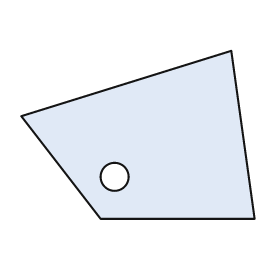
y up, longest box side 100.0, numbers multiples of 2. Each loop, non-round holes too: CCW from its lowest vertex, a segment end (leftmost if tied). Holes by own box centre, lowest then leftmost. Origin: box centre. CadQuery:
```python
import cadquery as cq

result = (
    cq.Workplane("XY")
    .moveTo(-16.0, -36.0)
    .lineTo(50.0, -36.0)
    .lineTo(40.0, 36.0)
    .lineTo(-50.0, 8.0)
    .close()
    .moveTo(-10.0, -18.0)
    .circle(6.0)
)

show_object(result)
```